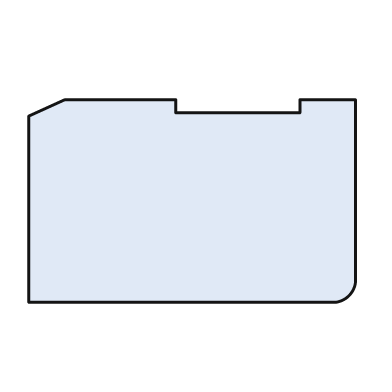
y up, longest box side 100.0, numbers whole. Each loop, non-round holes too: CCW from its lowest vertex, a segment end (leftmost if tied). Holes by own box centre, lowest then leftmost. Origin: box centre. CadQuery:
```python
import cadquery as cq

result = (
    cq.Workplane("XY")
    .moveTo(-50.0, -31.0)
    .lineTo(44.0, -31.0)
    .threePointArc((48.0, -29.0), (50.0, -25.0))
    .lineTo(50.0, 31.0)
    .lineTo(33.0, 31.0)
    .lineTo(33.0, 27.0)
    .lineTo(-5.0, 27.0)
    .lineTo(-5.0, 31.0)
    .lineTo(-39.0, 31.0)
    .lineTo(-50.0, 26.0)
    .close()
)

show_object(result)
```